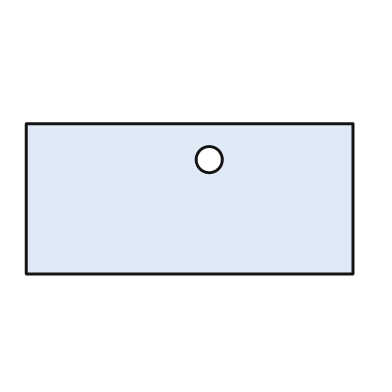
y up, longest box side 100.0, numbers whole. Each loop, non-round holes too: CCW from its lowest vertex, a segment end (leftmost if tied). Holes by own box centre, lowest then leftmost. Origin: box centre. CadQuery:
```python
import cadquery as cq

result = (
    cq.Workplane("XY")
    .moveTo(-50.0, -23.0)
    .lineTo(50.0, -23.0)
    .lineTo(50.0, 23.0)
    .lineTo(-50.0, 23.0)
    .close()
    .moveTo(6.0, 12.0)
    .circle(4.0)
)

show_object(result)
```